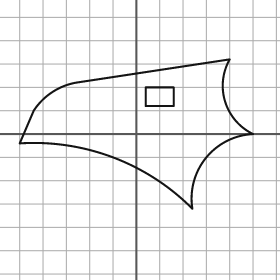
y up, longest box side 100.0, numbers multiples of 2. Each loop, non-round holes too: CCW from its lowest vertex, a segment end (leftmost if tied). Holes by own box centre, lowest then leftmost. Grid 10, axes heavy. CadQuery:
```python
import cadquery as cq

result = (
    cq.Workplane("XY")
    .moveTo(24.0, -32.0)
    .threePointArc((30.0, -10.0), (50.0, 0.0))
    .threePointArc((38.0, 14.0), (40.0, 32.0))
    .lineTo(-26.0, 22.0)
    .threePointArc((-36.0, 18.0), (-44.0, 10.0))
    .lineTo(-50.0, -4.0)
    .threePointArc((-10.0, -10.0), (24.0, -32.0))
    .close()
    .moveTo(4.0, 12.0)
    .lineTo(16.0, 12.0)
    .lineTo(16.0, 20.0)
    .lineTo(4.0, 20.0)
    .close()
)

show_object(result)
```